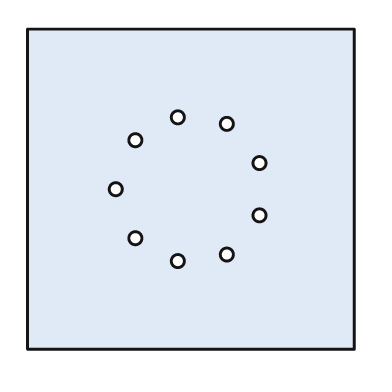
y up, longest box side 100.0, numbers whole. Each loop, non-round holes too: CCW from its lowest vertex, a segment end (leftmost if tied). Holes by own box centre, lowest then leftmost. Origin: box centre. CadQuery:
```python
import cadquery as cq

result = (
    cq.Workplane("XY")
    .moveTo(-50.0, -49.0)
    .lineTo(50.0, -49.0)
    .lineTo(50.0, 49.0)
    .lineTo(-50.0, 49.0)
    .close()
    .moveTo(-4.0, -22.0)
    .circle(2.0)
    .moveTo(11.0, -20.0)
    .circle(2.0)
    .moveTo(-17.0, -15.0)
    .circle(2.0)
    .moveTo(21.0, -8.0)
    .circle(2.0)
    .moveTo(-23.0, 0.0)
    .circle(2.0)
    .moveTo(21.0, 8.0)
    .circle(2.0)
    .moveTo(-17.0, 15.0)
    .circle(2.0)
    .moveTo(11.0, 20.0)
    .circle(2.0)
    .moveTo(-4.0, 22.0)
    .circle(2.0)
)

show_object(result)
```